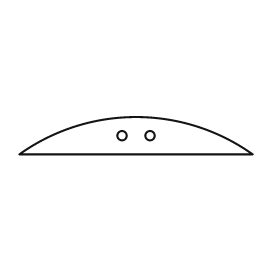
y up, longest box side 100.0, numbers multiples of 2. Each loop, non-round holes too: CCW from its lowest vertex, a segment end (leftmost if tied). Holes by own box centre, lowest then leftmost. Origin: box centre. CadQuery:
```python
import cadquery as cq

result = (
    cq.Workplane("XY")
    .moveTo(-50.0, -8.0)
    .lineTo(50.0, -8.0)
    .threePointArc((0.0, 8.0), (-50.0, -8.0))
    .close()
    .moveTo(-6.0, 0.0)
    .circle(2.0)
    .moveTo(6.0, 0.0)
    .circle(2.0)
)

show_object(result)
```